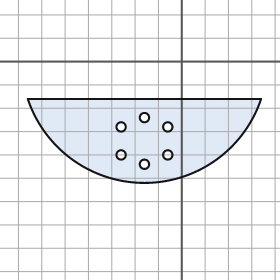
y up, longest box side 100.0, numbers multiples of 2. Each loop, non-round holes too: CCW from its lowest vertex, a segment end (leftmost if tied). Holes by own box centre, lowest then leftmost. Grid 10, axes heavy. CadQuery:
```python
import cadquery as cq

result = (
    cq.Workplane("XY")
    .moveTo(-66.0, -16.0)
    .threePointArc((-16.0, -52.0), (34.0, -16.0))
    .close()
    .moveTo(-16.0, -44.0)
    .circle(2.0)
    .moveTo(-26.0, -40.0)
    .circle(2.0)
    .moveTo(-6.0, -40.0)
    .circle(2.0)
    .moveTo(-26.0, -28.0)
    .circle(2.0)
    .moveTo(-6.0, -28.0)
    .circle(2.0)
    .moveTo(-16.0, -24.0)
    .circle(2.0)
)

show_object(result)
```